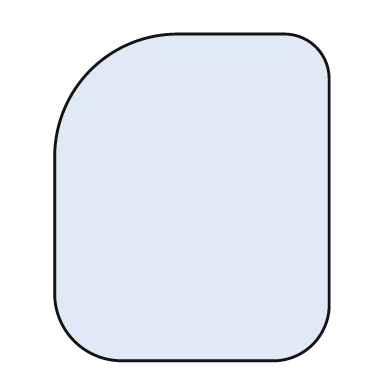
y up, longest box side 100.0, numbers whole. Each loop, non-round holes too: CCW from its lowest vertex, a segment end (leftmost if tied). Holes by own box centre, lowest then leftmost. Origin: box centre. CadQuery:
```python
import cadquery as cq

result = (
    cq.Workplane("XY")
    .moveTo(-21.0, -50.0)
    .lineTo(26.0, -50.0)
    .threePointArc((37.0, -45.0), (42.0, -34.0))
    .lineTo(42.0, 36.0)
    .threePointArc((38.0, 46.0), (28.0, 50.0))
    .lineTo(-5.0, 50.0)
    .threePointArc((-31.0, 39.0), (-42.0, 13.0))
    .lineTo(-42.0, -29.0)
    .threePointArc((-36.0, -44.0), (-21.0, -50.0))
    .close()
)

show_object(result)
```